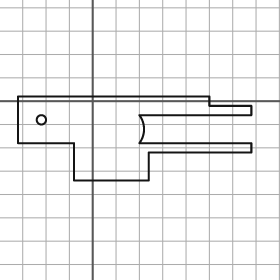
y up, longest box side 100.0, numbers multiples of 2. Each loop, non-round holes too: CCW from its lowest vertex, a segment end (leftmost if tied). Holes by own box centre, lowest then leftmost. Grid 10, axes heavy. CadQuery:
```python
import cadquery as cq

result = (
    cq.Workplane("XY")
    .moveTo(-8.0, -34.0)
    .lineTo(24.0, -34.0)
    .lineTo(24.0, -22.0)
    .lineTo(68.0, -22.0)
    .lineTo(68.0, -18.0)
    .lineTo(20.0, -18.0)
    .threePointArc((22.0, -12.0), (20.0, -6.0))
    .lineTo(68.0, -6.0)
    .lineTo(68.0, -2.0)
    .lineTo(50.0, -2.0)
    .lineTo(50.0, 2.0)
    .lineTo(-32.0, 2.0)
    .lineTo(-32.0, -18.0)
    .lineTo(-8.0, -18.0)
    .close()
    .moveTo(-22.0, -8.0)
    .circle(2.0)
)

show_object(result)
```